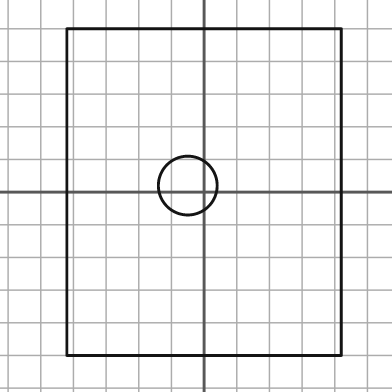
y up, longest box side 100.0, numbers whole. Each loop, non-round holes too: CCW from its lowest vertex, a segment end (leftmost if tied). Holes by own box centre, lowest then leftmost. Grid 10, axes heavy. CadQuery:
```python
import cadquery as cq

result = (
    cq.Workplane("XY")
    .moveTo(-42.0, -50.0)
    .lineTo(42.0, -50.0)
    .lineTo(42.0, 50.0)
    .lineTo(-42.0, 50.0)
    .close()
    .moveTo(-5.0, 2.0)
    .circle(9.0)
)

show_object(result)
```